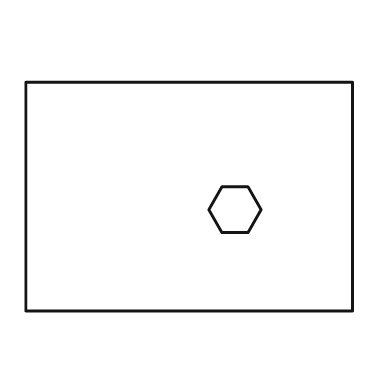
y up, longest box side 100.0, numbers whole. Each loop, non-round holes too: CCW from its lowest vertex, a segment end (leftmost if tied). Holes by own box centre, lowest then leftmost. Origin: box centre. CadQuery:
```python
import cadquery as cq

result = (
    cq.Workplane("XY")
    .moveTo(-50.0, -35.0)
    .lineTo(50.0, -35.0)
    .lineTo(50.0, 35.0)
    .lineTo(-50.0, 35.0)
    .close()
    .moveTo(10.0, -11.0)
    .lineTo(18.0, -11.0)
    .lineTo(22.0, -4.0)
    .lineTo(18.0, 3.0)
    .lineTo(10.0, 3.0)
    .lineTo(6.0, -4.0)
    .close()
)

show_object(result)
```